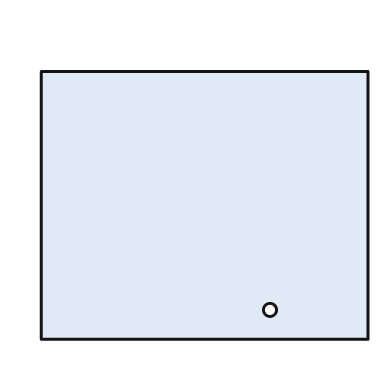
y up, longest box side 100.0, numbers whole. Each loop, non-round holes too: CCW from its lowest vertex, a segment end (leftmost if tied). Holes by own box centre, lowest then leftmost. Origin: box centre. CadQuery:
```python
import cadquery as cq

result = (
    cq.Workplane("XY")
    .moveTo(-50.0, -41.0)
    .lineTo(50.0, -41.0)
    .lineTo(50.0, 41.0)
    .lineTo(-50.0, 41.0)
    .close()
    .moveTo(20.0, -32.0)
    .circle(2.0)
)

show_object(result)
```